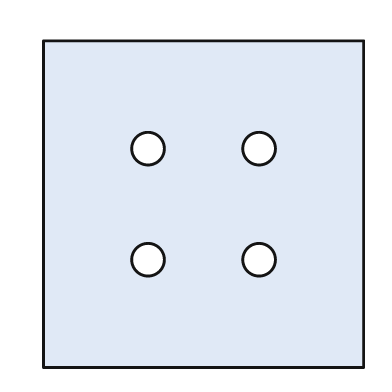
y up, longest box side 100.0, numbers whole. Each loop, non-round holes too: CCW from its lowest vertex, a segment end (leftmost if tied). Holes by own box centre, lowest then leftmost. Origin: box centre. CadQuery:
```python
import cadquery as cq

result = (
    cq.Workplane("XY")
    .moveTo(-49.0, -50.0)
    .lineTo(49.0, -50.0)
    .lineTo(49.0, 50.0)
    .lineTo(-49.0, 50.0)
    .close()
    .moveTo(-17.0, -17.0)
    .circle(5.0)
    .moveTo(17.0, -17.0)
    .circle(5.0)
    .moveTo(-17.0, 17.0)
    .circle(5.0)
    .moveTo(17.0, 17.0)
    .circle(5.0)
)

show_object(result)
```